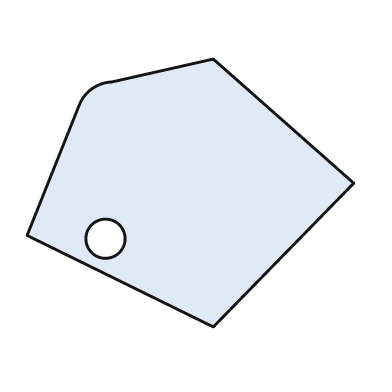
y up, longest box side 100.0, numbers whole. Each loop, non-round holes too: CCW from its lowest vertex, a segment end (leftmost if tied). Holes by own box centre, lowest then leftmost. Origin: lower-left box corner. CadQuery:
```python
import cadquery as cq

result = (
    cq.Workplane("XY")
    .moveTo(57.0, 0.0)
    .lineTo(100.0, 44.0)
    .lineTo(57.0, 82.0)
    .lineTo(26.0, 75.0)
    .threePointArc((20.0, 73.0), (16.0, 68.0))
    .lineTo(0.0, 28.0)
    .close()
    .moveTo(24.0, 27.0)
    .circle(6.0)
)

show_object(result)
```